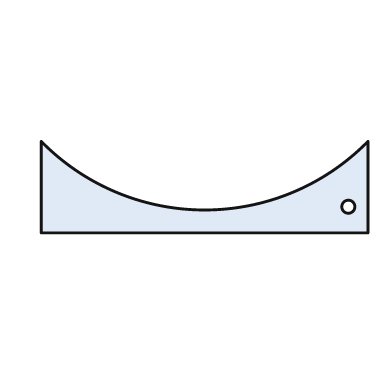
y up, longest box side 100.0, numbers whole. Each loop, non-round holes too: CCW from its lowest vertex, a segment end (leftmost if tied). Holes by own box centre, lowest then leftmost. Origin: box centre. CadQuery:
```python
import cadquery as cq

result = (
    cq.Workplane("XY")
    .moveTo(-50.0, -14.0)
    .lineTo(50.0, -14.0)
    .lineTo(50.0, 14.0)
    .threePointArc((0.0, -7.0), (-50.0, 14.0))
    .close()
    .moveTo(44.0, -6.0)
    .circle(2.0)
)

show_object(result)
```